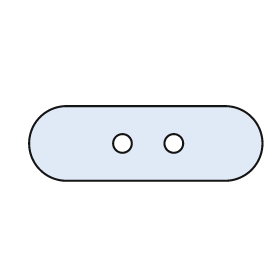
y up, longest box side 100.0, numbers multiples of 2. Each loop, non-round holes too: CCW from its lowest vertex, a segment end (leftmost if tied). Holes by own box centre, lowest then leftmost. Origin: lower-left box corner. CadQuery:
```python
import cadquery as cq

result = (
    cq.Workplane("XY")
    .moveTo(16.0, 0.0)
    .lineTo(84.0, 0.0)
    .threePointArc((100.0, 16.0), (84.0, 32.0))
    .lineTo(16.0, 32.0)
    .threePointArc((0.0, 16.0), (16.0, 0.0))
    .close()
    .moveTo(40.0, 16.0)
    .circle(4.0)
    .moveTo(62.0, 16.0)
    .circle(4.0)
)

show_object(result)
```